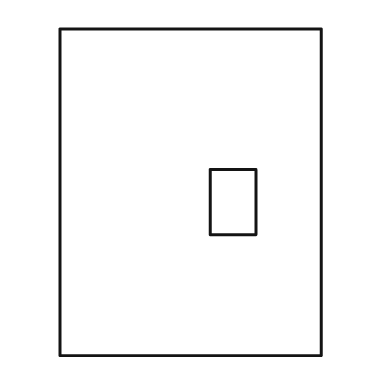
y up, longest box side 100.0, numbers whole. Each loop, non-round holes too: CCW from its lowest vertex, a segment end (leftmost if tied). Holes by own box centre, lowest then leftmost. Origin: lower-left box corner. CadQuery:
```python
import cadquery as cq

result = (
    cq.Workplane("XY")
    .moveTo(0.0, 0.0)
    .lineTo(80.0, 0.0)
    .lineTo(80.0, 100.0)
    .lineTo(0.0, 100.0)
    .close()
    .moveTo(46.0, 37.0)
    .lineTo(60.0, 37.0)
    .lineTo(60.0, 57.0)
    .lineTo(46.0, 57.0)
    .close()
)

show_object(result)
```